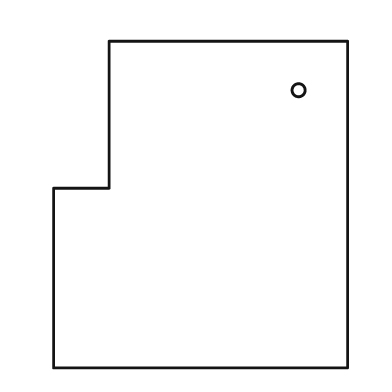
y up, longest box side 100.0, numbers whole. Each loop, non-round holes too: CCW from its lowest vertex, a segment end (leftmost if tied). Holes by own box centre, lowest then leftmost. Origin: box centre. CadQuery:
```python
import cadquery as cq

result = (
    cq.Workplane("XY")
    .moveTo(-45.0, -50.0)
    .lineTo(45.0, -50.0)
    .lineTo(45.0, 50.0)
    .lineTo(-28.0, 50.0)
    .lineTo(-28.0, 5.0)
    .lineTo(-45.0, 5.0)
    .close()
    .moveTo(30.0, 35.0)
    .circle(2.0)
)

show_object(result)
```